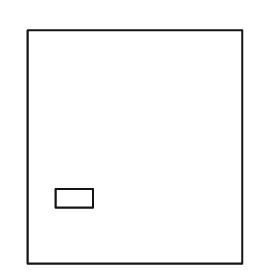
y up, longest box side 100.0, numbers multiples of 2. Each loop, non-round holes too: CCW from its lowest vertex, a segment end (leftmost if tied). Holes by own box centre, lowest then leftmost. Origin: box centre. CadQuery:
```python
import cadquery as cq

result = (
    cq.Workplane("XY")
    .moveTo(-46.0, -50.0)
    .lineTo(46.0, -50.0)
    .lineTo(46.0, 50.0)
    .lineTo(-46.0, 50.0)
    .close()
    .moveTo(-34.0, -26.0)
    .lineTo(-18.0, -26.0)
    .lineTo(-18.0, -18.0)
    .lineTo(-34.0, -18.0)
    .close()
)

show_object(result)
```